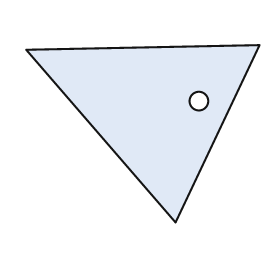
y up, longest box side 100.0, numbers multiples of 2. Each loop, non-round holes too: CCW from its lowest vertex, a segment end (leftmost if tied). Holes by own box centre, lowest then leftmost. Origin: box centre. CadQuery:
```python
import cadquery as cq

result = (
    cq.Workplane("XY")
    .moveTo(14.0, -38.0)
    .lineTo(50.0, 38.0)
    .lineTo(-50.0, 36.0)
    .close()
    .moveTo(24.0, 14.0)
    .circle(4.0)
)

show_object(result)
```